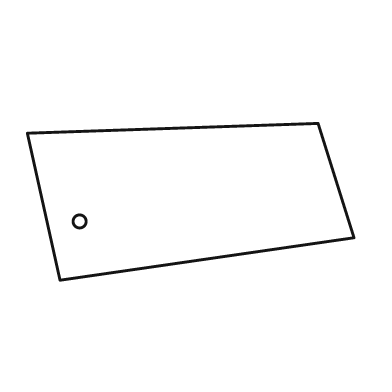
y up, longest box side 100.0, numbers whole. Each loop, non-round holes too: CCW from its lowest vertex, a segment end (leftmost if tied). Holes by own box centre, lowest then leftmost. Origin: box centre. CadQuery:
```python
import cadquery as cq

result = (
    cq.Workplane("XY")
    .moveTo(-40.0, -24.0)
    .lineTo(50.0, -11.0)
    .lineTo(39.0, 24.0)
    .lineTo(-50.0, 21.0)
    .close()
    .moveTo(-34.0, -6.0)
    .circle(2.0)
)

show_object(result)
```